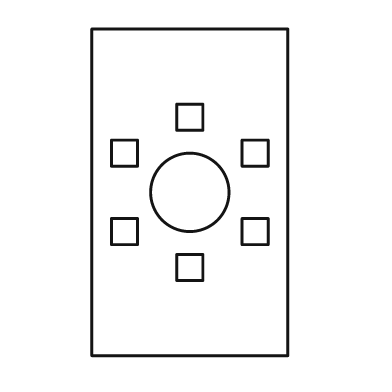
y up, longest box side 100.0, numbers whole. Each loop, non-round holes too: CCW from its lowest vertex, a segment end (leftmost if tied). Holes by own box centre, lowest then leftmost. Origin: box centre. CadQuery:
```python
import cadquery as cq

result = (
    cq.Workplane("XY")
    .moveTo(-30.0, -50.0)
    .lineTo(30.0, -50.0)
    .lineTo(30.0, 50.0)
    .lineTo(-30.0, 50.0)
    .close()
    .moveTo(-4.0, -27.0)
    .lineTo(4.0, -27.0)
    .lineTo(4.0, -19.0)
    .lineTo(-4.0, -19.0)
    .close()
    .moveTo(-24.0, -16.0)
    .lineTo(-16.0, -16.0)
    .lineTo(-16.0, -8.0)
    .lineTo(-24.0, -8.0)
    .close()
    .moveTo(16.0, -16.0)
    .lineTo(24.0, -16.0)
    .lineTo(24.0, -8.0)
    .lineTo(16.0, -8.0)
    .close()
    .moveTo(0.0, 0.0)
    .circle(12.0)
    .moveTo(-24.0, 8.0)
    .lineTo(-16.0, 8.0)
    .lineTo(-16.0, 16.0)
    .lineTo(-24.0, 16.0)
    .close()
    .moveTo(16.0, 8.0)
    .lineTo(24.0, 8.0)
    .lineTo(24.0, 16.0)
    .lineTo(16.0, 16.0)
    .close()
    .moveTo(-4.0, 19.0)
    .lineTo(4.0, 19.0)
    .lineTo(4.0, 27.0)
    .lineTo(-4.0, 27.0)
    .close()
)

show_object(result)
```